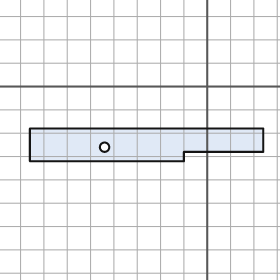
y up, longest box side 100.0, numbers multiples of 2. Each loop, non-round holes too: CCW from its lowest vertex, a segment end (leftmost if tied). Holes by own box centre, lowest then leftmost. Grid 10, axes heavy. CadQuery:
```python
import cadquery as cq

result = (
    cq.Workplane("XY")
    .moveTo(-76.0, -32.0)
    .lineTo(-10.0, -32.0)
    .lineTo(-10.0, -28.0)
    .lineTo(24.0, -28.0)
    .lineTo(24.0, -18.0)
    .lineTo(-76.0, -18.0)
    .close()
    .moveTo(-44.0, -26.0)
    .circle(2.0)
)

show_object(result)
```